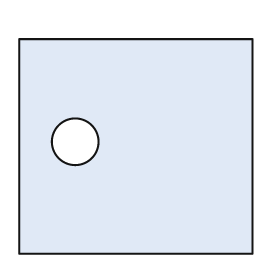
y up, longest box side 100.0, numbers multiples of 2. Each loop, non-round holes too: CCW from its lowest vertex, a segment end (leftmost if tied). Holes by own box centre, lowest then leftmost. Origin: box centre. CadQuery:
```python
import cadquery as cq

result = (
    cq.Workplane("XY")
    .moveTo(-50.0, -46.0)
    .lineTo(50.0, -46.0)
    .lineTo(50.0, 46.0)
    .lineTo(-50.0, 46.0)
    .close()
    .moveTo(-26.0, 2.0)
    .circle(10.0)
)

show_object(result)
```